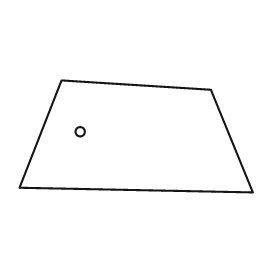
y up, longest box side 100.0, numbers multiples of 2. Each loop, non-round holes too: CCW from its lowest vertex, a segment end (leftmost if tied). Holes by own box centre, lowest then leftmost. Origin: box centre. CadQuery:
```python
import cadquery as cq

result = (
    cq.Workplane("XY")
    .moveTo(50.0, -24.0)
    .lineTo(32.0, 20.0)
    .lineTo(-32.0, 24.0)
    .lineTo(-50.0, -22.0)
    .close()
    .moveTo(-24.0, 2.0)
    .circle(2.0)
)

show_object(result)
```